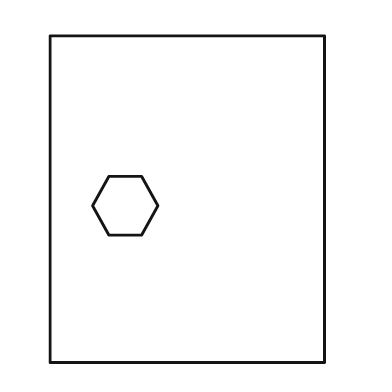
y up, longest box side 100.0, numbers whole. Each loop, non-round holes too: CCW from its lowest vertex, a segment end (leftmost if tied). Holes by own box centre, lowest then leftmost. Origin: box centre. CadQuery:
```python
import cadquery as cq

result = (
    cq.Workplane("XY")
    .moveTo(-42.0, -50.0)
    .lineTo(42.0, -50.0)
    .lineTo(42.0, 50.0)
    .lineTo(-42.0, 50.0)
    .close()
    .moveTo(-24.0, -11.0)
    .lineTo(-14.0, -11.0)
    .lineTo(-9.0, -2.0)
    .lineTo(-14.0, 7.0)
    .lineTo(-24.0, 7.0)
    .lineTo(-29.0, -2.0)
    .close()
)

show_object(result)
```